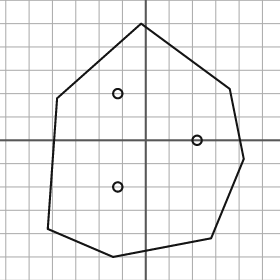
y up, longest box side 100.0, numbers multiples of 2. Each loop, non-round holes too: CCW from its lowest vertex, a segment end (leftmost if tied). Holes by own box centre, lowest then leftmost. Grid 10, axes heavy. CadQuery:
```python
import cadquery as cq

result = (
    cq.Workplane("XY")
    .moveTo(-14.0, -50.0)
    .lineTo(28.0, -42.0)
    .lineTo(42.0, -8.0)
    .lineTo(36.0, 22.0)
    .lineTo(-2.0, 50.0)
    .lineTo(-38.0, 18.0)
    .lineTo(-42.0, -38.0)
    .close()
    .moveTo(-12.0, -20.0)
    .circle(2.0)
    .moveTo(22.0, 0.0)
    .circle(2.0)
    .moveTo(-12.0, 20.0)
    .circle(2.0)
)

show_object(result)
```